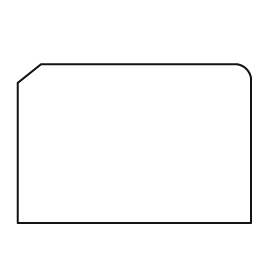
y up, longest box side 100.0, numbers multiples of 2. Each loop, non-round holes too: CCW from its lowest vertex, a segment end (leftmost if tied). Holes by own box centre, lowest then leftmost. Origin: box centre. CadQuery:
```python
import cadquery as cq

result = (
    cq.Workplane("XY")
    .moveTo(-50.0, -34.0)
    .lineTo(50.0, -34.0)
    .lineTo(50.0, 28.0)
    .threePointArc((48.0, 32.0), (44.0, 34.0))
    .lineTo(-40.0, 34.0)
    .lineTo(-50.0, 26.0)
    .close()
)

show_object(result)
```